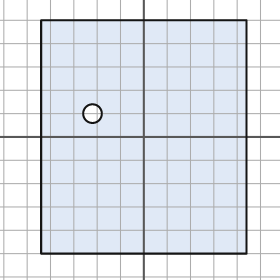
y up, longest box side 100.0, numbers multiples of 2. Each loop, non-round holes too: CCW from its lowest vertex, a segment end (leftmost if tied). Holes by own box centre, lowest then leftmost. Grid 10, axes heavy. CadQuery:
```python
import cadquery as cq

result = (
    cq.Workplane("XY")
    .moveTo(-44.0, -50.0)
    .lineTo(44.0, -50.0)
    .lineTo(44.0, 50.0)
    .lineTo(-44.0, 50.0)
    .close()
    .moveTo(-22.0, 10.0)
    .circle(4.0)
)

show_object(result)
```